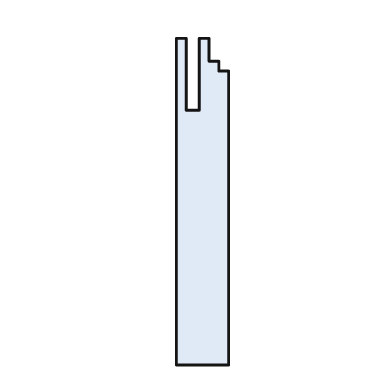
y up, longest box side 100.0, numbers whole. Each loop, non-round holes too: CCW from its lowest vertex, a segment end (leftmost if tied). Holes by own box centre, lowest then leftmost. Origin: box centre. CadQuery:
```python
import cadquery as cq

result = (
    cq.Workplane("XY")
    .moveTo(-8.0, -50.0)
    .lineTo(8.0, -50.0)
    .lineTo(8.0, 40.0)
    .lineTo(5.0, 40.0)
    .lineTo(5.0, 43.0)
    .lineTo(2.0, 43.0)
    .lineTo(2.0, 50.0)
    .lineTo(-1.0, 50.0)
    .lineTo(-1.0, 28.0)
    .lineTo(-5.0, 28.0)
    .lineTo(-5.0, 50.0)
    .lineTo(-8.0, 50.0)
    .close()
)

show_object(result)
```